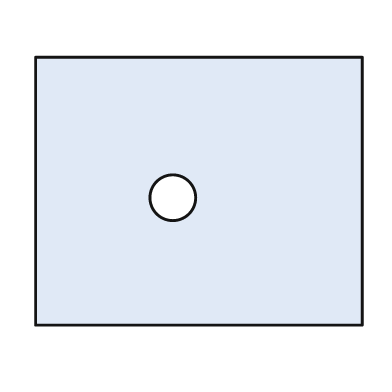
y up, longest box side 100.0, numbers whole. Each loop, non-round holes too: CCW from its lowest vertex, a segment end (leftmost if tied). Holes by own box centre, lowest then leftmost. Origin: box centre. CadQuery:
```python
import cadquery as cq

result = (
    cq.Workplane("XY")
    .moveTo(-50.0, -41.0)
    .lineTo(50.0, -41.0)
    .lineTo(50.0, 41.0)
    .lineTo(-50.0, 41.0)
    .close()
    .moveTo(-8.0, -2.0)
    .circle(7.0)
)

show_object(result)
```